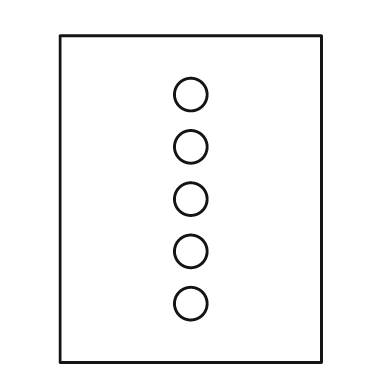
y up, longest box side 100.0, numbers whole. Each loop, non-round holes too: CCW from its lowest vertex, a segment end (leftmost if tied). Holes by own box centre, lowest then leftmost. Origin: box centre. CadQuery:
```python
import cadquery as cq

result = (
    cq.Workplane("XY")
    .moveTo(-40.0, -50.0)
    .lineTo(40.0, -50.0)
    .lineTo(40.0, 50.0)
    .lineTo(-40.0, 50.0)
    .close()
    .moveTo(0.0, -32.0)
    .circle(5.0)
    .moveTo(0.0, -16.0)
    .circle(5.0)
    .moveTo(0.0, 0.0)
    .circle(5.0)
    .moveTo(0.0, 16.0)
    .circle(5.0)
    .moveTo(0.0, 32.0)
    .circle(5.0)
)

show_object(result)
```